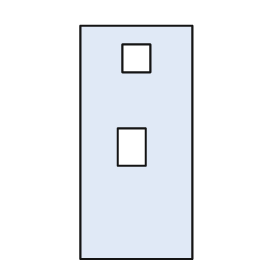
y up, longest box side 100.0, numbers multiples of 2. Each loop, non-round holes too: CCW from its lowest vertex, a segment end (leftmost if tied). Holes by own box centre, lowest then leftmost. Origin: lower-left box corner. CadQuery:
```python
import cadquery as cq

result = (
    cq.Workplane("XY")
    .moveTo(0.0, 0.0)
    .lineTo(48.0, 0.0)
    .lineTo(48.0, 100.0)
    .lineTo(0.0, 100.0)
    .close()
    .moveTo(16.0, 40.0)
    .lineTo(28.0, 40.0)
    .lineTo(28.0, 56.0)
    .lineTo(16.0, 56.0)
    .close()
    .moveTo(18.0, 80.0)
    .lineTo(30.0, 80.0)
    .lineTo(30.0, 92.0)
    .lineTo(18.0, 92.0)
    .close()
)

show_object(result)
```